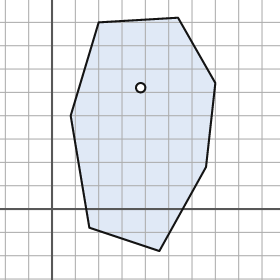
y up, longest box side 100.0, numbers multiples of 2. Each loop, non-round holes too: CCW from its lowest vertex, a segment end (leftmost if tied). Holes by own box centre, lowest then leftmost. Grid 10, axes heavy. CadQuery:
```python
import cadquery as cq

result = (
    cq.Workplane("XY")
    .moveTo(46.0, -18.0)
    .lineTo(66.0, 18.0)
    .lineTo(70.0, 54.0)
    .lineTo(54.0, 82.0)
    .lineTo(20.0, 80.0)
    .lineTo(8.0, 40.0)
    .lineTo(16.0, -8.0)
    .close()
    .moveTo(38.0, 52.0)
    .circle(2.0)
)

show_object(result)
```